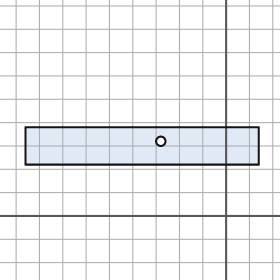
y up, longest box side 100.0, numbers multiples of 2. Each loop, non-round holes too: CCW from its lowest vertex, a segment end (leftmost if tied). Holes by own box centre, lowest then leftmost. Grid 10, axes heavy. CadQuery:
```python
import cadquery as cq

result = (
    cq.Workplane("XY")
    .moveTo(-86.0, 22.0)
    .lineTo(14.0, 22.0)
    .lineTo(14.0, 38.0)
    .lineTo(-86.0, 38.0)
    .close()
    .moveTo(-28.0, 32.0)
    .circle(2.0)
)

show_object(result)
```